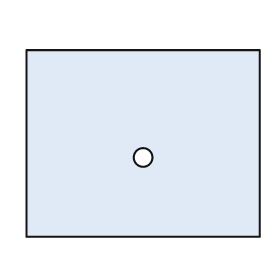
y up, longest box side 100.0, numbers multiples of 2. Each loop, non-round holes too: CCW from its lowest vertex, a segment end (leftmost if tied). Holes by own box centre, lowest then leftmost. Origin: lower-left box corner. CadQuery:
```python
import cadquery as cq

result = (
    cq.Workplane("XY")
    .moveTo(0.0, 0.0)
    .lineTo(100.0, 0.0)
    .lineTo(100.0, 80.0)
    .lineTo(0.0, 80.0)
    .close()
    .moveTo(50.0, 34.0)
    .circle(4.0)
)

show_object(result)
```